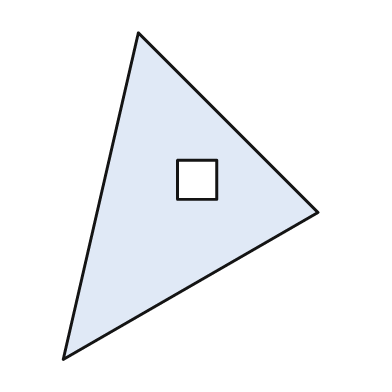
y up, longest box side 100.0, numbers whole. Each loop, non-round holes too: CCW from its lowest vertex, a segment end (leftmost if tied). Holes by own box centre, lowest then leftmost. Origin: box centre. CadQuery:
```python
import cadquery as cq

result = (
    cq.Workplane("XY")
    .moveTo(-39.0, -50.0)
    .lineTo(39.0, -5.0)
    .lineTo(-16.0, 50.0)
    .close()
    .moveTo(-4.0, -1.0)
    .lineTo(8.0, -1.0)
    .lineTo(8.0, 11.0)
    .lineTo(-4.0, 11.0)
    .close()
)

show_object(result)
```